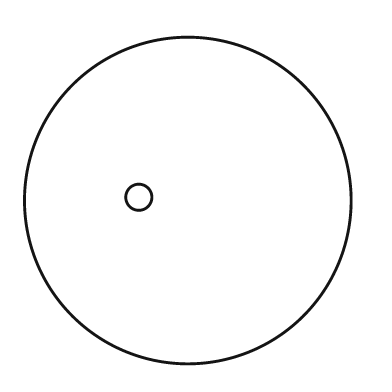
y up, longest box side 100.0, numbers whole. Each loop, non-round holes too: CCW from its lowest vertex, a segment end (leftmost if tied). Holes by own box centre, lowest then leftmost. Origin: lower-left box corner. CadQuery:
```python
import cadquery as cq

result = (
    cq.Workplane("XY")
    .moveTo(50.0, 50.0)
    .circle(50.0)
    .moveTo(35.0, 51.0)
    .circle(4.0)
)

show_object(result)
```